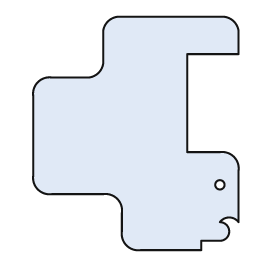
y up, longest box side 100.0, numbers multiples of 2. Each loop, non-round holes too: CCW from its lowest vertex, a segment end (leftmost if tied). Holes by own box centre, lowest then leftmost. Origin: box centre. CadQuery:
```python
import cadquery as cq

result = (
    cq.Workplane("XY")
    .moveTo(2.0, -50.0)
    .lineTo(28.0, -50.0)
    .lineTo(28.0, -46.0)
    .lineTo(36.0, -46.0)
    .threePointArc((40.0, -42.0), (36.0, -38.0))
    .threePointArc((40.0, -36.0), (44.0, -38.0))
    .lineTo(44.0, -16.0)
    .threePointArc((42.0, -10.0), (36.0, -8.0))
    .lineTo(22.0, -8.0)
    .lineTo(22.0, 34.0)
    .lineTo(44.0, 34.0)
    .lineTo(44.0, 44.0)
    .threePointArc((42.0, 48.0), (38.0, 50.0))
    .lineTo(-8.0, 50.0)
    .threePointArc((-12.0, 48.0), (-14.0, 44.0))
    .lineTo(-14.0, 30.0)
    .threePointArc((-16.0, 26.0), (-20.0, 24.0))
    .lineTo(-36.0, 24.0)
    .threePointArc((-42.0, 22.0), (-44.0, 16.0))
    .lineTo(-44.0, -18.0)
    .threePointArc((-42.0, -24.0), (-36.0, -26.0))
    .lineTo(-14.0, -26.0)
    .threePointArc((-8.0, -28.0), (-6.0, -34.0))
    .lineTo(-6.0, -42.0)
    .threePointArc((-4.0, -48.0), (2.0, -50.0))
    .close()
    .moveTo(36.0, -22.0)
    .circle(2.0)
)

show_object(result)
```